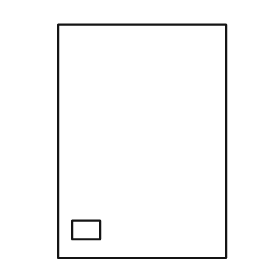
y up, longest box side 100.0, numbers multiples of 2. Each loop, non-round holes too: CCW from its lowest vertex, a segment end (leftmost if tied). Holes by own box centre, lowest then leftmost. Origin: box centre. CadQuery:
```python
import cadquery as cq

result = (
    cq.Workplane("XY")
    .moveTo(-36.0, -50.0)
    .lineTo(36.0, -50.0)
    .lineTo(36.0, 50.0)
    .lineTo(-36.0, 50.0)
    .close()
    .moveTo(-30.0, -42.0)
    .lineTo(-18.0, -42.0)
    .lineTo(-18.0, -34.0)
    .lineTo(-30.0, -34.0)
    .close()
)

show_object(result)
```